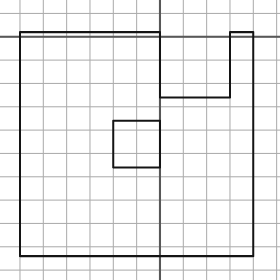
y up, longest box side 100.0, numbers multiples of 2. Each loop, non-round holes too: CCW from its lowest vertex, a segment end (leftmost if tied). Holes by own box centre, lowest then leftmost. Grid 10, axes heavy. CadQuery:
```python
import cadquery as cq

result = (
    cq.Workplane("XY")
    .moveTo(-60.0, -94.0)
    .lineTo(40.0, -94.0)
    .lineTo(40.0, 2.0)
    .lineTo(30.0, 2.0)
    .lineTo(30.0, -26.0)
    .lineTo(0.0, -26.0)
    .lineTo(0.0, 2.0)
    .lineTo(-60.0, 2.0)
    .close()
    .moveTo(-20.0, -56.0)
    .lineTo(0.0, -56.0)
    .lineTo(0.0, -36.0)
    .lineTo(-20.0, -36.0)
    .close()
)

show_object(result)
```